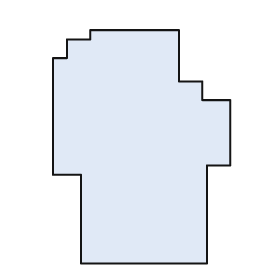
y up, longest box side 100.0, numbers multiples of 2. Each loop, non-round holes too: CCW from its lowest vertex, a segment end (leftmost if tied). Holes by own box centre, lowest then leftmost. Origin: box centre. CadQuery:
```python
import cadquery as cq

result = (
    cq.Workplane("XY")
    .moveTo(-26.0, -50.0)
    .lineTo(28.0, -50.0)
    .lineTo(28.0, -8.0)
    .lineTo(38.0, -8.0)
    .lineTo(38.0, 20.0)
    .lineTo(26.0, 20.0)
    .lineTo(26.0, 28.0)
    .lineTo(16.0, 28.0)
    .lineTo(16.0, 50.0)
    .lineTo(-22.0, 50.0)
    .lineTo(-22.0, 46.0)
    .lineTo(-32.0, 46.0)
    .lineTo(-32.0, 38.0)
    .lineTo(-38.0, 38.0)
    .lineTo(-38.0, -12.0)
    .lineTo(-26.0, -12.0)
    .close()
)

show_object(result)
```